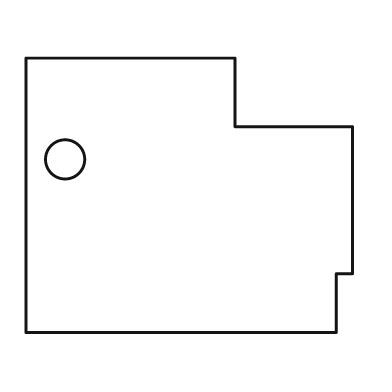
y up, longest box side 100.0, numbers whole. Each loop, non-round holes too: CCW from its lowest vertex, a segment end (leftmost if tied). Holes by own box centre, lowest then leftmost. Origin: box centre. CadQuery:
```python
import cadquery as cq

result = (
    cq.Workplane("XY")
    .moveTo(-50.0, -42.0)
    .lineTo(45.0, -42.0)
    .lineTo(45.0, -24.0)
    .lineTo(50.0, -24.0)
    .lineTo(50.0, 21.0)
    .lineTo(14.0, 21.0)
    .lineTo(14.0, 42.0)
    .lineTo(-50.0, 42.0)
    .close()
    .moveTo(-38.0, 11.0)
    .circle(6.0)
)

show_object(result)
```